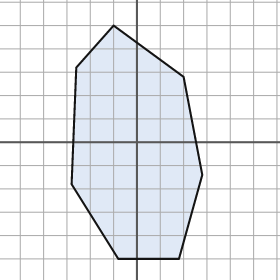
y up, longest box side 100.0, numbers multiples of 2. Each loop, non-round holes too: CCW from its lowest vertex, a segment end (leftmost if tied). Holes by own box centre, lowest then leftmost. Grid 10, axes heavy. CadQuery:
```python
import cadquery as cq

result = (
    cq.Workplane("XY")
    .moveTo(-8.0, -50.0)
    .lineTo(18.0, -50.0)
    .lineTo(28.0, -14.0)
    .lineTo(20.0, 28.0)
    .lineTo(-10.0, 50.0)
    .lineTo(-26.0, 32.0)
    .lineTo(-28.0, -18.0)
    .close()
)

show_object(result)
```